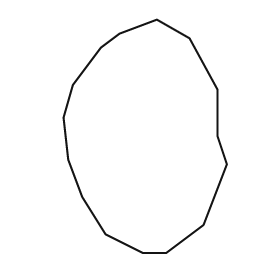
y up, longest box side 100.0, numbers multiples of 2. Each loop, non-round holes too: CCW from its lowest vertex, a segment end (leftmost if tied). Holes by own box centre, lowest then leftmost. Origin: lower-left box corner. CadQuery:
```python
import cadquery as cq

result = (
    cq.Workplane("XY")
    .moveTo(34.0, 0.0)
    .lineTo(44.0, 0.0)
    .lineTo(60.0, 12.0)
    .lineTo(70.0, 38.0)
    .lineTo(66.0, 50.0)
    .lineTo(66.0, 70.0)
    .lineTo(54.0, 92.0)
    .lineTo(40.0, 100.0)
    .lineTo(24.0, 94.0)
    .lineTo(16.0, 88.0)
    .lineTo(4.0, 72.0)
    .lineTo(0.0, 58.0)
    .lineTo(2.0, 40.0)
    .lineTo(8.0, 24.0)
    .lineTo(18.0, 8.0)
    .close()
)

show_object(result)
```